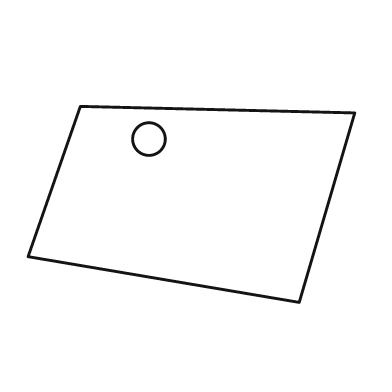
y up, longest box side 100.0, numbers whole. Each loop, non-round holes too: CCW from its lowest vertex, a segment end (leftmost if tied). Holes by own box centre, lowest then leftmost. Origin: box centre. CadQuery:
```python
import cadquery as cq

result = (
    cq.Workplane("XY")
    .moveTo(33.0, -30.0)
    .lineTo(50.0, 28.0)
    .lineTo(-34.0, 30.0)
    .lineTo(-50.0, -16.0)
    .close()
    .moveTo(-13.0, 20.0)
    .circle(5.0)
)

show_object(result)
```